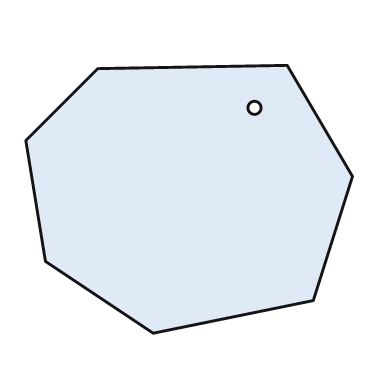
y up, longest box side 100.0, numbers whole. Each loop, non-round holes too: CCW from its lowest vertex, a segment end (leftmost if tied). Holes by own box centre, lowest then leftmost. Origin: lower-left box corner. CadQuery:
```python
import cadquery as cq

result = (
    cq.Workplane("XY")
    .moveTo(39.0, 0.0)
    .lineTo(88.0, 10.0)
    .lineTo(100.0, 48.0)
    .lineTo(80.0, 82.0)
    .lineTo(22.0, 81.0)
    .lineTo(0.0, 59.0)
    .lineTo(6.0, 22.0)
    .close()
    .moveTo(70.0, 69.0)
    .circle(2.0)
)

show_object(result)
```